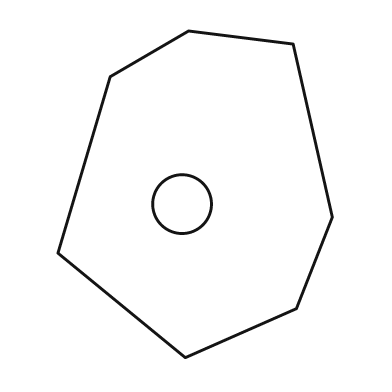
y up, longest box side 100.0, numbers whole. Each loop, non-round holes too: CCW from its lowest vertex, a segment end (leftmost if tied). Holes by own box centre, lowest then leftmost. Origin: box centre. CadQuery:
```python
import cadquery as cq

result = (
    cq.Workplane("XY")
    .moveTo(-3.0, -50.0)
    .lineTo(31.0, -35.0)
    .lineTo(42.0, -7.0)
    .lineTo(30.0, 46.0)
    .lineTo(-2.0, 50.0)
    .lineTo(-26.0, 36.0)
    .lineTo(-42.0, -18.0)
    .close()
    .moveTo(-4.0, -3.0)
    .circle(9.0)
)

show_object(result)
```